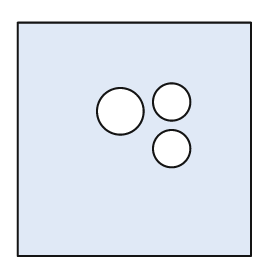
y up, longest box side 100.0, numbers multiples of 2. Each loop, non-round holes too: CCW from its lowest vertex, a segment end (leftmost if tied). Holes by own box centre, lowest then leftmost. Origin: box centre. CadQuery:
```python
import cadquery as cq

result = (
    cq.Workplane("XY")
    .moveTo(-50.0, -50.0)
    .lineTo(50.0, -50.0)
    .lineTo(50.0, 50.0)
    .lineTo(-50.0, 50.0)
    .close()
    .moveTo(16.0, -4.0)
    .circle(8.0)
    .moveTo(-6.0, 12.0)
    .circle(10.0)
    .moveTo(16.0, 16.0)
    .circle(8.0)
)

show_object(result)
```